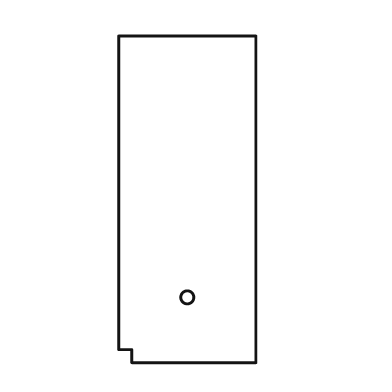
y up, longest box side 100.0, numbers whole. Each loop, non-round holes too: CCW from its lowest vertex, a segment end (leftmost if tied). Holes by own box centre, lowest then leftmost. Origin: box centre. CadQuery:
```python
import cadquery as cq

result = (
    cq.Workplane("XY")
    .moveTo(-17.0, -50.0)
    .lineTo(21.0, -50.0)
    .lineTo(21.0, 50.0)
    .lineTo(-21.0, 50.0)
    .lineTo(-21.0, -46.0)
    .lineTo(-17.0, -46.0)
    .close()
    .moveTo(0.0, -30.0)
    .circle(2.0)
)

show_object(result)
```